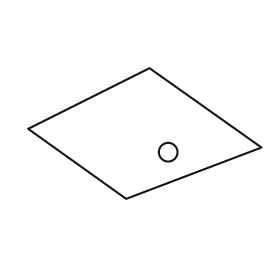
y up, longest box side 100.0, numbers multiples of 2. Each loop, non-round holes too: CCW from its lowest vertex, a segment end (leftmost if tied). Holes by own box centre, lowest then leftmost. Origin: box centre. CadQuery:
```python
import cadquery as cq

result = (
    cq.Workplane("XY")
    .moveTo(-8.0, -28.0)
    .lineTo(50.0, -6.0)
    .lineTo(2.0, 28.0)
    .lineTo(-50.0, 2.0)
    .close()
    .moveTo(10.0, -8.0)
    .circle(4.0)
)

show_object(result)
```